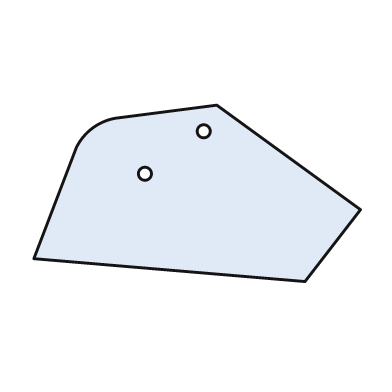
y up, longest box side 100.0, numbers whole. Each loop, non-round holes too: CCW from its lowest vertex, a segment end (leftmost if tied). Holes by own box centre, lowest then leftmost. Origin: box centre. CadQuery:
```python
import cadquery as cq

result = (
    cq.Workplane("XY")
    .moveTo(33.0, -27.0)
    .lineTo(50.0, -5.0)
    .lineTo(6.0, 27.0)
    .lineTo(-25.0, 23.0)
    .threePointArc((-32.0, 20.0), (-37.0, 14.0))
    .lineTo(-50.0, -20.0)
    .close()
    .moveTo(-16.0, 6.0)
    .circle(2.0)
    .moveTo(2.0, 19.0)
    .circle(2.0)
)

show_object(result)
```